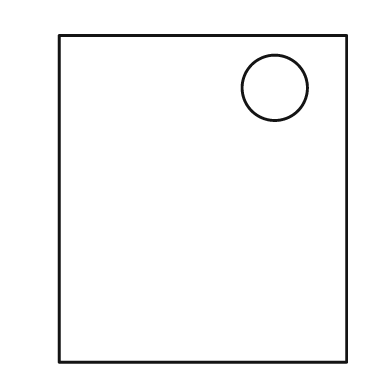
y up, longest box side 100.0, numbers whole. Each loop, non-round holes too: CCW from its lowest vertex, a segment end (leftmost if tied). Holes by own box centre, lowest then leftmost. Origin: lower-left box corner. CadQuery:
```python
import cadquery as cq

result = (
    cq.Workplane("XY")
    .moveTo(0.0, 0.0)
    .lineTo(88.0, 0.0)
    .lineTo(88.0, 100.0)
    .lineTo(0.0, 100.0)
    .close()
    .moveTo(66.0, 84.0)
    .circle(10.0)
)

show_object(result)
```